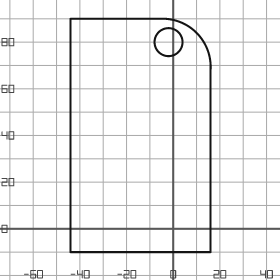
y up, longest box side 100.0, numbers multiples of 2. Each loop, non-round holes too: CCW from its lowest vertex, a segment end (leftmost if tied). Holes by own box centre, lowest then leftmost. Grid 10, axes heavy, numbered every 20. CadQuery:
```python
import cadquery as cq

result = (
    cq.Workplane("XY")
    .moveTo(-44.0, -10.0)
    .lineTo(16.0, -10.0)
    .lineTo(16.0, 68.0)
    .threePointArc((10.0, 84.0), (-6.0, 90.0))
    .lineTo(-44.0, 90.0)
    .close()
    .moveTo(-2.0, 80.0)
    .circle(6.0)
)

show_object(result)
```